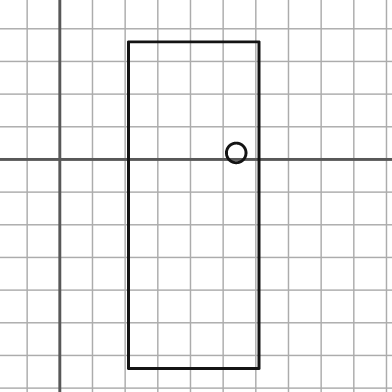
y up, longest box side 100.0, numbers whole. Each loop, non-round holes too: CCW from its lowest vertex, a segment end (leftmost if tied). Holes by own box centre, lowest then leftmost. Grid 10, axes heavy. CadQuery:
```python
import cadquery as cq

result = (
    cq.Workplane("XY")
    .moveTo(21.0, -64.0)
    .lineTo(61.0, -64.0)
    .lineTo(61.0, 36.0)
    .lineTo(21.0, 36.0)
    .close()
    .moveTo(54.0, 2.0)
    .circle(3.0)
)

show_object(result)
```